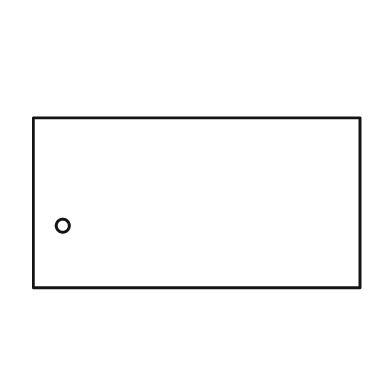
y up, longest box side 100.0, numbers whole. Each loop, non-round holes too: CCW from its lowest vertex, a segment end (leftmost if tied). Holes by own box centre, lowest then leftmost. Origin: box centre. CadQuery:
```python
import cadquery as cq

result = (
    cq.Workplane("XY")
    .moveTo(-50.0, -26.0)
    .lineTo(50.0, -26.0)
    .lineTo(50.0, 26.0)
    .lineTo(-50.0, 26.0)
    .close()
    .moveTo(-41.0, -7.0)
    .circle(2.0)
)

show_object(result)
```